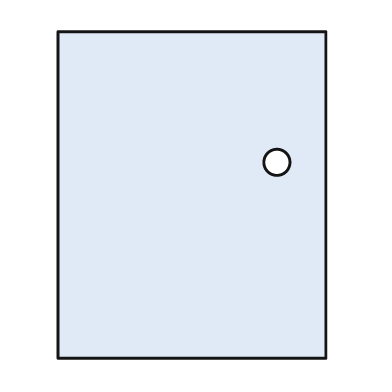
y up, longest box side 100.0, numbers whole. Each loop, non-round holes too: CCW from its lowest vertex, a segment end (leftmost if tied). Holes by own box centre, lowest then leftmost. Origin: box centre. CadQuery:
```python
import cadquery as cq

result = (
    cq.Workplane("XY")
    .moveTo(-41.0, -50.0)
    .lineTo(41.0, -50.0)
    .lineTo(41.0, 50.0)
    .lineTo(-41.0, 50.0)
    .close()
    .moveTo(26.0, 10.0)
    .circle(4.0)
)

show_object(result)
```